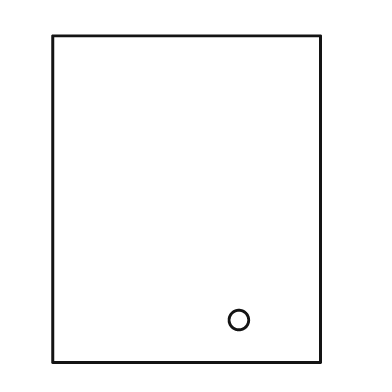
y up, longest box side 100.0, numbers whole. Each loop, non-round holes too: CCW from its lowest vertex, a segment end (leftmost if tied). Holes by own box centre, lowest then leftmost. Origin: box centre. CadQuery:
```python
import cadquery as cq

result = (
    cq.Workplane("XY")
    .moveTo(-41.0, -50.0)
    .lineTo(41.0, -50.0)
    .lineTo(41.0, 50.0)
    .lineTo(-41.0, 50.0)
    .close()
    .moveTo(16.0, -37.0)
    .circle(3.0)
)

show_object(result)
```